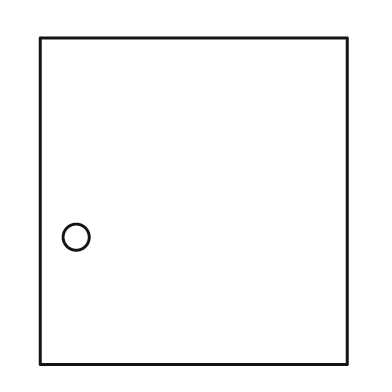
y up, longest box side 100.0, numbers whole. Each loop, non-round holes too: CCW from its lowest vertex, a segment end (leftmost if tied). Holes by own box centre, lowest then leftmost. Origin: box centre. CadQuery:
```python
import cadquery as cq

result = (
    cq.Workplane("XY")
    .moveTo(-47.0, -50.0)
    .lineTo(47.0, -50.0)
    .lineTo(47.0, 50.0)
    .lineTo(-47.0, 50.0)
    .close()
    .moveTo(-36.0, -11.0)
    .circle(4.0)
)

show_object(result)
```